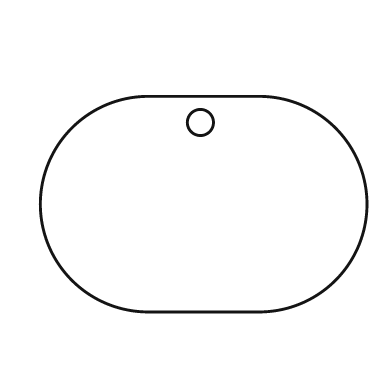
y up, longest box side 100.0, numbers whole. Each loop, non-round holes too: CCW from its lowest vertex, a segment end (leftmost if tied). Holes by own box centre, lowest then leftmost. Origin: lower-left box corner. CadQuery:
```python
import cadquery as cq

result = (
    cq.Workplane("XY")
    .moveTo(33.0, 0.0)
    .lineTo(67.0, 0.0)
    .threePointArc((100.0, 33.0), (67.0, 66.0))
    .lineTo(33.0, 66.0)
    .threePointArc((0.0, 33.0), (33.0, 0.0))
    .close()
    .moveTo(49.0, 58.0)
    .circle(4.0)
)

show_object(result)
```